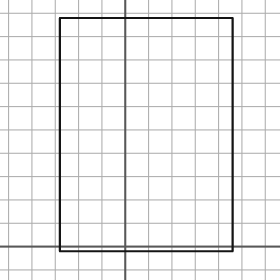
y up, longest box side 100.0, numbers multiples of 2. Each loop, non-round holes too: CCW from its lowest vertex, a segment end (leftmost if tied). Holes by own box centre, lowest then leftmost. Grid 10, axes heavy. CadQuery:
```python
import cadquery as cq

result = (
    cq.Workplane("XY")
    .moveTo(-28.0, -2.0)
    .lineTo(46.0, -2.0)
    .lineTo(46.0, 98.0)
    .lineTo(-28.0, 98.0)
    .close()
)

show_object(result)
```